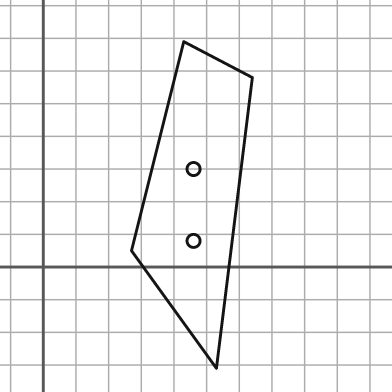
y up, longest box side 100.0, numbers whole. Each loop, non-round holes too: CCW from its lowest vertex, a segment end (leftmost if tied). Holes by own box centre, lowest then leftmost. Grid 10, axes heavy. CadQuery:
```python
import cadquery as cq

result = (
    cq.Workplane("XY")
    .moveTo(53.0, -31.0)
    .lineTo(64.0, 58.0)
    .lineTo(43.0, 69.0)
    .lineTo(27.0, 5.0)
    .close()
    .moveTo(46.0, 8.0)
    .circle(2.0)
    .moveTo(46.0, 30.0)
    .circle(2.0)
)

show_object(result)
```